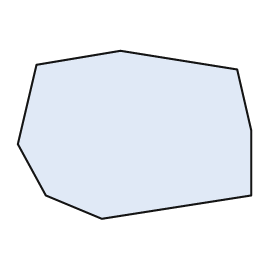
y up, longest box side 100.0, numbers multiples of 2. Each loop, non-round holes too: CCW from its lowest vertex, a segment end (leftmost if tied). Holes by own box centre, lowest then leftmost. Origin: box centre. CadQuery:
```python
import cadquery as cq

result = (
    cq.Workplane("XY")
    .moveTo(-14.0, -36.0)
    .lineTo(50.0, -26.0)
    .lineTo(50.0, 2.0)
    .lineTo(44.0, 28.0)
    .lineTo(-6.0, 36.0)
    .lineTo(-42.0, 30.0)
    .lineTo(-50.0, -4.0)
    .lineTo(-38.0, -26.0)
    .close()
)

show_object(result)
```